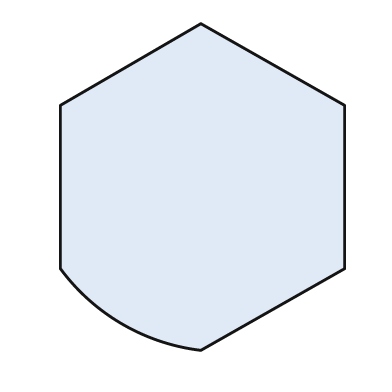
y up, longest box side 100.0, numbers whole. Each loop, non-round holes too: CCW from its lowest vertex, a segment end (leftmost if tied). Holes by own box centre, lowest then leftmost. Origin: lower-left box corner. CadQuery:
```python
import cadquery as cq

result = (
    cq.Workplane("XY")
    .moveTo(43.0, 0.0)
    .lineTo(87.0, 25.0)
    .lineTo(87.0, 75.0)
    .lineTo(43.0, 100.0)
    .lineTo(0.0, 75.0)
    .lineTo(0.0, 25.0)
    .threePointArc((19.0, 8.0), (43.0, 0.0))
    .close()
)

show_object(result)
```